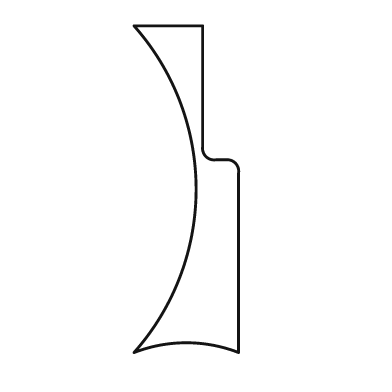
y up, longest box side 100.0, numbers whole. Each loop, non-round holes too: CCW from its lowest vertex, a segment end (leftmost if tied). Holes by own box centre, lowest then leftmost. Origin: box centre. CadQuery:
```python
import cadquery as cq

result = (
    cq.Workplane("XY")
    .moveTo(-16.0, -50.0)
    .threePointArc((0.0, -47.0), (16.0, -50.0))
    .lineTo(16.0, 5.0)
    .threePointArc((15.0, 8.0), (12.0, 9.0))
    .lineTo(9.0, 9.0)
    .threePointArc((6.0, 10.0), (5.0, 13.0))
    .lineTo(5.0, 50.0)
    .lineTo(-16.0, 50.0)
    .threePointArc((3.0, 0.0), (-16.0, -50.0))
    .close()
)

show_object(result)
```